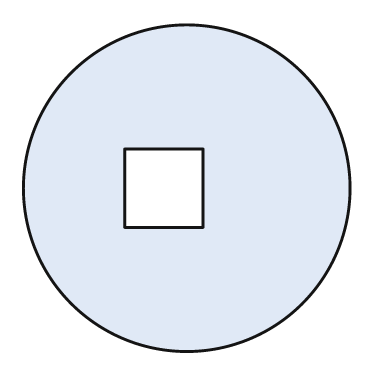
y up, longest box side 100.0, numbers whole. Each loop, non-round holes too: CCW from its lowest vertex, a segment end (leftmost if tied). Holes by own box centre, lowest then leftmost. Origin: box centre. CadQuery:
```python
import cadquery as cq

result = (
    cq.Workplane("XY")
    .moveTo(0.0, 0.0)
    .circle(50.0)
    .moveTo(-19.0, -12.0)
    .lineTo(5.0, -12.0)
    .lineTo(5.0, 12.0)
    .lineTo(-19.0, 12.0)
    .close()
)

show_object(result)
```